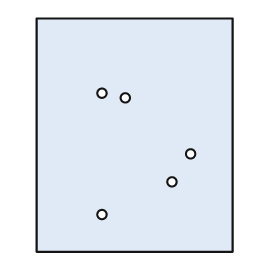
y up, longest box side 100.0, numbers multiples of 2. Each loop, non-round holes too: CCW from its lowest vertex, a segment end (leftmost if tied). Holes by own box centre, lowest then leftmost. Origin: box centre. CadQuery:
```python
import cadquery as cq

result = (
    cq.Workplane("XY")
    .moveTo(-42.0, -50.0)
    .lineTo(42.0, -50.0)
    .lineTo(42.0, 50.0)
    .lineTo(-42.0, 50.0)
    .close()
    .moveTo(-14.0, -34.0)
    .circle(2.0)
    .moveTo(16.0, -20.0)
    .circle(2.0)
    .moveTo(24.0, -8.0)
    .circle(2.0)
    .moveTo(-4.0, 16.0)
    .circle(2.0)
    .moveTo(-14.0, 18.0)
    .circle(2.0)
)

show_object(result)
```